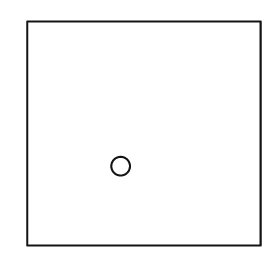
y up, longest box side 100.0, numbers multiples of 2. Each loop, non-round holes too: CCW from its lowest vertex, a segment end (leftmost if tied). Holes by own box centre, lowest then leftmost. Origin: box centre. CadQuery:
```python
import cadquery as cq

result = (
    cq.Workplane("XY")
    .moveTo(-50.0, -48.0)
    .lineTo(50.0, -48.0)
    .lineTo(50.0, 48.0)
    .lineTo(-50.0, 48.0)
    .close()
    .moveTo(-10.0, -14.0)
    .circle(4.0)
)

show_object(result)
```